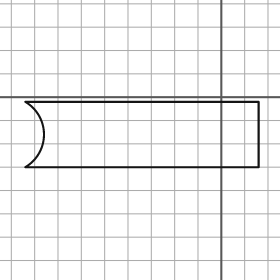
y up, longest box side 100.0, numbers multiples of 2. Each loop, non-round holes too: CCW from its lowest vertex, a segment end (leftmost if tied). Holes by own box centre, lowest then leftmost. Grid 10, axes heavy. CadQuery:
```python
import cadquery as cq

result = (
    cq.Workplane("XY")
    .moveTo(-84.0, -30.0)
    .lineTo(16.0, -30.0)
    .lineTo(16.0, -2.0)
    .lineTo(-84.0, -2.0)
    .threePointArc((-76.0, -16.0), (-84.0, -30.0))
    .close()
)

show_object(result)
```